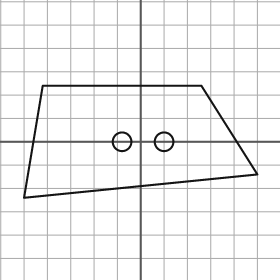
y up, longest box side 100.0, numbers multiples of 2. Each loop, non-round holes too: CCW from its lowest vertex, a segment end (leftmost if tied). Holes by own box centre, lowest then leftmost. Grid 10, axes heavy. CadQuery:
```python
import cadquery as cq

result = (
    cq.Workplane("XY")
    .moveTo(-50.0, -24.0)
    .lineTo(50.0, -14.0)
    .lineTo(26.0, 24.0)
    .lineTo(-42.0, 24.0)
    .close()
    .moveTo(-8.0, 0.0)
    .circle(4.0)
    .moveTo(10.0, 0.0)
    .circle(4.0)
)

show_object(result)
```